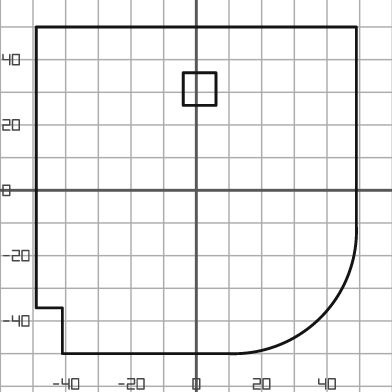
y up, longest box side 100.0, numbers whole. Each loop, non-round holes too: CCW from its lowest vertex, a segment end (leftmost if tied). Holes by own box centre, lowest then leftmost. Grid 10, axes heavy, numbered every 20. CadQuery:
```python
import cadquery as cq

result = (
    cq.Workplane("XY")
    .moveTo(-41.0, -50.0)
    .lineTo(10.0, -50.0)
    .threePointArc((38.0, -39.0), (49.0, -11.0))
    .lineTo(49.0, 50.0)
    .lineTo(-49.0, 50.0)
    .lineTo(-49.0, -36.0)
    .lineTo(-41.0, -36.0)
    .close()
    .moveTo(-4.0, 26.0)
    .lineTo(6.0, 26.0)
    .lineTo(6.0, 36.0)
    .lineTo(-4.0, 36.0)
    .close()
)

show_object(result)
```